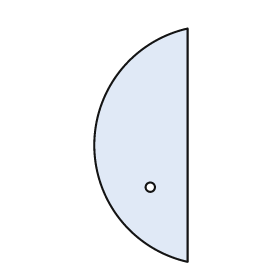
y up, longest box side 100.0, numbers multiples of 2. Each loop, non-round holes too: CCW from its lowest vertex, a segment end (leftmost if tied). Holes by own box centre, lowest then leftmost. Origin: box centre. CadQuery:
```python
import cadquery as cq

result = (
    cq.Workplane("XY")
    .moveTo(20.0, -50.0)
    .lineTo(20.0, 50.0)
    .threePointArc((-20.0, 0.0), (20.0, -50.0))
    .close()
    .moveTo(4.0, -18.0)
    .circle(2.0)
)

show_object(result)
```